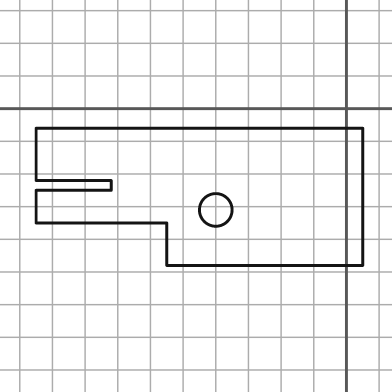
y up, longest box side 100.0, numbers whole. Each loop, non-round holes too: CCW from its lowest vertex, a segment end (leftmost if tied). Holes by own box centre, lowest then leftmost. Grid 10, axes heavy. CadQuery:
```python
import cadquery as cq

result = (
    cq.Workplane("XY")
    .moveTo(-55.0, -48.0)
    .lineTo(5.0, -48.0)
    .lineTo(5.0, -6.0)
    .lineTo(-95.0, -6.0)
    .lineTo(-95.0, -22.0)
    .lineTo(-72.0, -22.0)
    .lineTo(-72.0, -25.0)
    .lineTo(-95.0, -25.0)
    .lineTo(-95.0, -35.0)
    .lineTo(-55.0, -35.0)
    .close()
    .moveTo(-40.0, -31.0)
    .circle(5.0)
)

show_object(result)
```